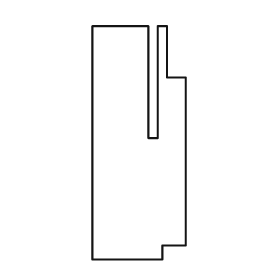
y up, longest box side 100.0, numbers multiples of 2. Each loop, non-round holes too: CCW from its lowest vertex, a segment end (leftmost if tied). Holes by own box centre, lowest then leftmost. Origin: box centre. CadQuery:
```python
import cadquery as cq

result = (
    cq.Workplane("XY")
    .moveTo(-20.0, -50.0)
    .lineTo(10.0, -50.0)
    .lineTo(10.0, -44.0)
    .lineTo(20.0, -44.0)
    .lineTo(20.0, 28.0)
    .lineTo(12.0, 28.0)
    .lineTo(12.0, 50.0)
    .lineTo(8.0, 50.0)
    .lineTo(8.0, 2.0)
    .lineTo(4.0, 2.0)
    .lineTo(4.0, 50.0)
    .lineTo(-20.0, 50.0)
    .close()
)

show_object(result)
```